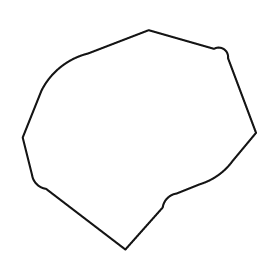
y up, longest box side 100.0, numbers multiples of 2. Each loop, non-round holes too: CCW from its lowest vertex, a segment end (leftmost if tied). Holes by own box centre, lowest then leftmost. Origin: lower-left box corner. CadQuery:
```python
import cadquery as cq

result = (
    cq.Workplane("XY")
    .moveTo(44.0, 0.0)
    .lineTo(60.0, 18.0)
    .threePointArc((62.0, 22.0), (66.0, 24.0))
    .lineTo(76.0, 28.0)
    .threePointArc((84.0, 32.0), (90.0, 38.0))
    .lineTo(100.0, 50.0)
    .lineTo(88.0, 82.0)
    .threePointArc((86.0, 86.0), (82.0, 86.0))
    .lineTo(54.0, 94.0)
    .lineTo(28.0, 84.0)
    .threePointArc((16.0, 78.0), (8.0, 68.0))
    .lineTo(0.0, 48.0)
    .lineTo(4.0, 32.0)
    .threePointArc((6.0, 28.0), (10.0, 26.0))
    .close()
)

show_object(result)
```